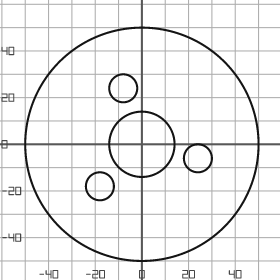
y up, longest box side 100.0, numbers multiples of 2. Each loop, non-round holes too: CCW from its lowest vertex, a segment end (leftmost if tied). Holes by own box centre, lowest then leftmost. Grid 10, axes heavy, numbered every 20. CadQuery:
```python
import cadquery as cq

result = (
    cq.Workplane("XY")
    .moveTo(0.0, 0.0)
    .circle(50.0)
    .moveTo(-18.0, -18.0)
    .circle(6.0)
    .moveTo(24.0, -6.0)
    .circle(6.0)
    .moveTo(0.0, 0.0)
    .circle(14.0)
    .moveTo(-8.0, 24.0)
    .circle(6.0)
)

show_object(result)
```